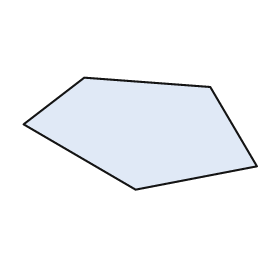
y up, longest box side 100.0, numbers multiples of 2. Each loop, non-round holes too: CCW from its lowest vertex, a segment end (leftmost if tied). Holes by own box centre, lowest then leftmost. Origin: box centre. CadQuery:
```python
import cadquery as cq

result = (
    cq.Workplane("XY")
    .moveTo(-2.0, -24.0)
    .lineTo(50.0, -14.0)
    .lineTo(30.0, 20.0)
    .lineTo(-24.0, 24.0)
    .lineTo(-50.0, 4.0)
    .close()
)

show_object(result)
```